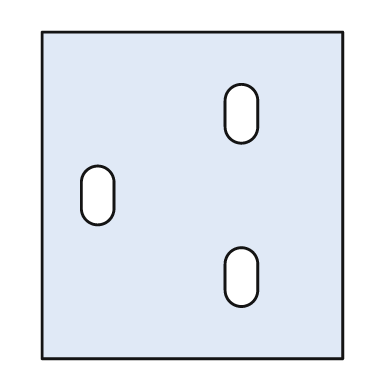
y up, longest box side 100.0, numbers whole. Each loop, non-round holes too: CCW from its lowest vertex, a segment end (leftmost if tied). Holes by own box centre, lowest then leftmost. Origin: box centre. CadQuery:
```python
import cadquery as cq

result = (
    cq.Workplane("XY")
    .moveTo(-46.0, -50.0)
    .lineTo(46.0, -50.0)
    .lineTo(46.0, 50.0)
    .lineTo(-46.0, 50.0)
    .close()
    .moveTo(10.0, -29.0)
    .threePointArc((15.0, -34.0), (20.0, -29.0))
    .lineTo(20.0, -21.0)
    .threePointArc((15.0, -16.0), (10.0, -21.0))
    .close()
    .moveTo(-34.0, -4.0)
    .threePointArc((-29.0, -9.0), (-24.0, -4.0))
    .lineTo(-24.0, 4.0)
    .threePointArc((-29.0, 9.0), (-34.0, 4.0))
    .close()
    .moveTo(10.0, 21.0)
    .threePointArc((15.0, 16.0), (20.0, 21.0))
    .lineTo(20.0, 29.0)
    .threePointArc((15.0, 34.0), (10.0, 29.0))
    .close()
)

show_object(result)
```